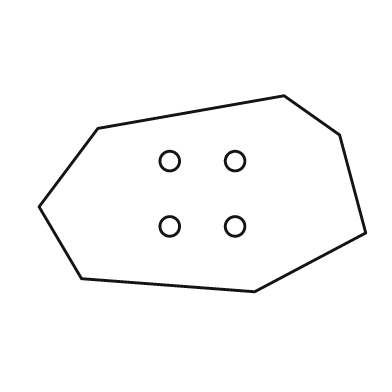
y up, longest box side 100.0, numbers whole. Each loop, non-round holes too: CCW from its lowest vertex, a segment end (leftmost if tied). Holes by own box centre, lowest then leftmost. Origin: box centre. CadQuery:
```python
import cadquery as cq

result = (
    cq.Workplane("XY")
    .moveTo(16.0, -30.0)
    .lineTo(50.0, -12.0)
    .lineTo(42.0, 18.0)
    .lineTo(25.0, 30.0)
    .lineTo(-32.0, 20.0)
    .lineTo(-50.0, -4.0)
    .lineTo(-37.0, -26.0)
    .close()
    .moveTo(-10.0, -10.0)
    .circle(3.0)
    .moveTo(10.0, -10.0)
    .circle(3.0)
    .moveTo(-10.0, 10.0)
    .circle(3.0)
    .moveTo(10.0, 10.0)
    .circle(3.0)
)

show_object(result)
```